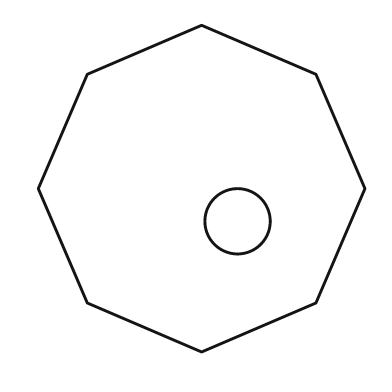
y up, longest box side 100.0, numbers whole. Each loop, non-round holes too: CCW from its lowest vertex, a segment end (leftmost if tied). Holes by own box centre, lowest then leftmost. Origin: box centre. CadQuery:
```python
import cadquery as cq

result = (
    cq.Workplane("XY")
    .moveTo(0.0, -50.0)
    .lineTo(35.0, -35.0)
    .lineTo(50.0, 0.0)
    .lineTo(35.0, 35.0)
    .lineTo(0.0, 50.0)
    .lineTo(-35.0, 35.0)
    .lineTo(-50.0, 0.0)
    .lineTo(-35.0, -35.0)
    .close()
    .moveTo(11.0, -10.0)
    .circle(10.0)
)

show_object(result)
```